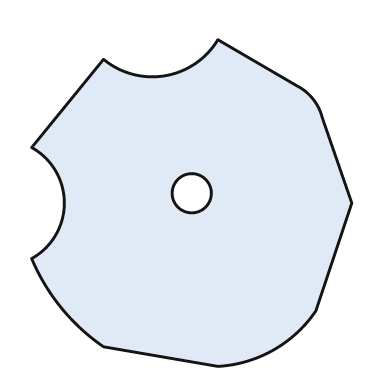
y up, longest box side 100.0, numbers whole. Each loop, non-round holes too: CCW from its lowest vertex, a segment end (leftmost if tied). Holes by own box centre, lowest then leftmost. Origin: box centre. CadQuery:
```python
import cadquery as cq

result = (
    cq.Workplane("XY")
    .moveTo(8.0, -50.0)
    .threePointArc((25.0, -45.0), (38.0, -33.0))
    .lineTo(49.0, 0.0)
    .lineTo(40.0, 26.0)
    .threePointArc((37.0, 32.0), (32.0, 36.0))
    .lineTo(8.0, 50.0)
    .threePointArc((-8.0, 39.0), (-27.0, 44.0))
    .lineTo(-49.0, 17.0)
    .threePointArc((-39.0, 0.0), (-49.0, -17.0))
    .threePointArc((-40.0, -32.0), (-27.0, -44.0))
    .close()
    .moveTo(0.0, 3.0)
    .circle(6.0)
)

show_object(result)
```